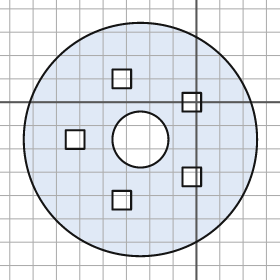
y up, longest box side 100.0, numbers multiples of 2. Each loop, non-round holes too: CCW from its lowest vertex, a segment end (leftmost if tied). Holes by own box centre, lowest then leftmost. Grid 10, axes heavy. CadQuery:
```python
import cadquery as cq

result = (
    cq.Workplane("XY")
    .moveTo(-24.0, -16.0)
    .circle(50.0)
    .moveTo(-36.0, -46.0)
    .lineTo(-28.0, -46.0)
    .lineTo(-28.0, -38.0)
    .lineTo(-36.0, -38.0)
    .close()
    .moveTo(-6.0, -36.0)
    .lineTo(2.0, -36.0)
    .lineTo(2.0, -28.0)
    .lineTo(-6.0, -28.0)
    .close()
    .moveTo(-56.0, -20.0)
    .lineTo(-48.0, -20.0)
    .lineTo(-48.0, -12.0)
    .lineTo(-56.0, -12.0)
    .close()
    .moveTo(-24.0, -16.0)
    .circle(12.0)
    .moveTo(-6.0, -4.0)
    .lineTo(2.0, -4.0)
    .lineTo(2.0, 4.0)
    .lineTo(-6.0, 4.0)
    .close()
    .moveTo(-36.0, 6.0)
    .lineTo(-28.0, 6.0)
    .lineTo(-28.0, 14.0)
    .lineTo(-36.0, 14.0)
    .close()
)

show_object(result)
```